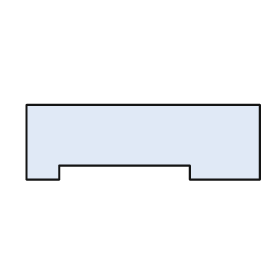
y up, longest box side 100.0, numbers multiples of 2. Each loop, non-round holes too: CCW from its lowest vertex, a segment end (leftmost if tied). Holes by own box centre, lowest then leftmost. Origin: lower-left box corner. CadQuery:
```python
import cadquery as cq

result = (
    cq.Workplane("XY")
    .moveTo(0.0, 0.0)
    .lineTo(14.0, 0.0)
    .lineTo(14.0, 6.0)
    .lineTo(70.0, 6.0)
    .lineTo(70.0, 0.0)
    .lineTo(100.0, 0.0)
    .lineTo(100.0, 32.0)
    .lineTo(0.0, 32.0)
    .close()
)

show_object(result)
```